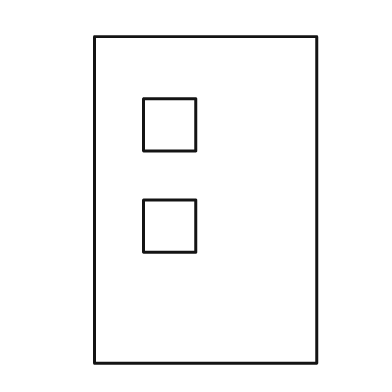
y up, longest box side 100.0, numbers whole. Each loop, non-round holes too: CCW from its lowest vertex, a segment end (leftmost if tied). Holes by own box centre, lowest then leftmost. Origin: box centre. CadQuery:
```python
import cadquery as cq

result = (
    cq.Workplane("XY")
    .moveTo(-34.0, -50.0)
    .lineTo(34.0, -50.0)
    .lineTo(34.0, 50.0)
    .lineTo(-34.0, 50.0)
    .close()
    .moveTo(-19.0, -16.0)
    .lineTo(-3.0, -16.0)
    .lineTo(-3.0, 0.0)
    .lineTo(-19.0, 0.0)
    .close()
    .moveTo(-19.0, 15.0)
    .lineTo(-3.0, 15.0)
    .lineTo(-3.0, 31.0)
    .lineTo(-19.0, 31.0)
    .close()
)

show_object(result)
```